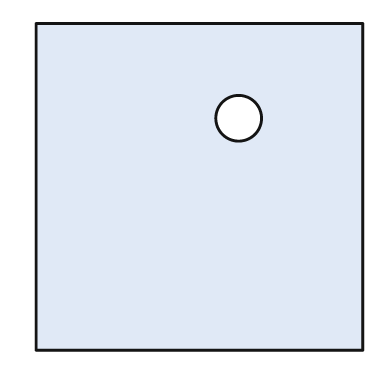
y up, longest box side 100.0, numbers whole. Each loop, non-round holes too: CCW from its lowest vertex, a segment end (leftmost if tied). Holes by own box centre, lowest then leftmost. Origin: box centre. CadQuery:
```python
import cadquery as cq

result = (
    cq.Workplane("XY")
    .moveTo(-50.0, -50.0)
    .lineTo(50.0, -50.0)
    .lineTo(50.0, 50.0)
    .lineTo(-50.0, 50.0)
    .close()
    .moveTo(12.0, 21.0)
    .circle(7.0)
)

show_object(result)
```